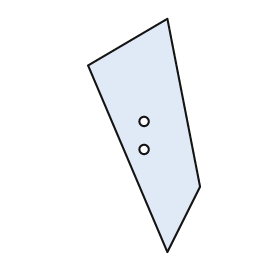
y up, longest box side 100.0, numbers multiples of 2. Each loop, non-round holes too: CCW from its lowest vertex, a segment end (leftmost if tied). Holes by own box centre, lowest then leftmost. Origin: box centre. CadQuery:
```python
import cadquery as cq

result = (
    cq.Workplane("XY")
    .moveTo(10.0, -50.0)
    .lineTo(24.0, -22.0)
    .lineTo(10.0, 50.0)
    .lineTo(-24.0, 30.0)
    .close()
    .moveTo(0.0, -6.0)
    .circle(2.0)
    .moveTo(0.0, 6.0)
    .circle(2.0)
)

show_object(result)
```